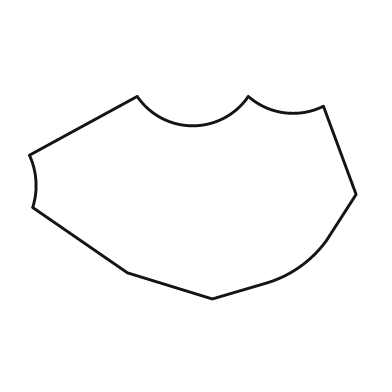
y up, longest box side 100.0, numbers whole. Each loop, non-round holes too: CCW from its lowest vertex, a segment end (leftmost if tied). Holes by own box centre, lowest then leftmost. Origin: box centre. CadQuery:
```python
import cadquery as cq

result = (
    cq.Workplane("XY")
    .moveTo(6.0, -31.0)
    .lineTo(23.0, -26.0)
    .threePointArc((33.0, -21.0), (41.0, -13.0))
    .lineTo(50.0, 1.0)
    .lineTo(40.0, 28.0)
    .threePointArc((28.0, 26.0), (17.0, 31.0))
    .threePointArc((0.0, 22.0), (-17.0, 31.0))
    .lineTo(-50.0, 13.0)
    .threePointArc((-48.0, 5.0), (-49.0, -3.0))
    .lineTo(-20.0, -23.0)
    .close()
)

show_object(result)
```